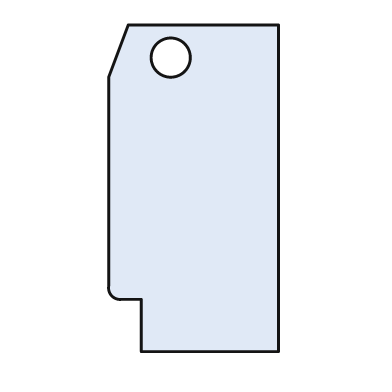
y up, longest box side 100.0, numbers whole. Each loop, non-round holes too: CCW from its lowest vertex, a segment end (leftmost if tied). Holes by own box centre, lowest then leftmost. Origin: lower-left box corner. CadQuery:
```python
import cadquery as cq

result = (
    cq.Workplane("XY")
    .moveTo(10.0, 0.0)
    .lineTo(52.0, 0.0)
    .lineTo(52.0, 100.0)
    .lineTo(6.0, 100.0)
    .lineTo(0.0, 84.0)
    .lineTo(0.0, 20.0)
    .threePointArc((1.0, 17.0), (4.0, 16.0))
    .lineTo(10.0, 16.0)
    .close()
    .moveTo(19.0, 90.0)
    .circle(6.0)
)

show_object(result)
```